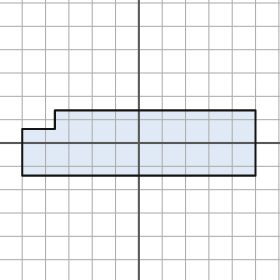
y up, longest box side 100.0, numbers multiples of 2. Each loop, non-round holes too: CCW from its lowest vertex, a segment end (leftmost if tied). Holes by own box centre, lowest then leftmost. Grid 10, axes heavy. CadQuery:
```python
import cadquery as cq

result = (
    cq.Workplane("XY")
    .moveTo(-50.0, -14.0)
    .lineTo(50.0, -14.0)
    .lineTo(50.0, 14.0)
    .lineTo(-36.0, 14.0)
    .lineTo(-36.0, 6.0)
    .lineTo(-50.0, 6.0)
    .close()
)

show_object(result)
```